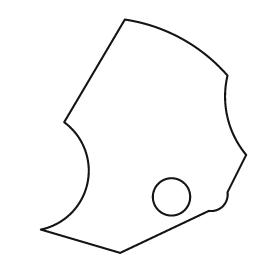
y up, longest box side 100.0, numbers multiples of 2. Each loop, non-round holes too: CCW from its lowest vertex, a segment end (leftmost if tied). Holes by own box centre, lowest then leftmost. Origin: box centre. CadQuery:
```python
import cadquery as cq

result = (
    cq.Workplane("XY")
    .moveTo(-10.0, -50.0)
    .lineTo(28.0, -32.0)
    .threePointArc((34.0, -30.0), (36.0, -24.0))
    .lineTo(44.0, -8.0)
    .threePointArc((36.0, 8.0), (36.0, 26.0))
    .threePointArc((16.0, 42.0), (-8.0, 50.0))
    .lineTo(-34.0, 6.0)
    .threePointArc((-24.0, -20.0), (-44.0, -40.0))
    .close()
    .moveTo(12.0, -26.0)
    .circle(8.0)
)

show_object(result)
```